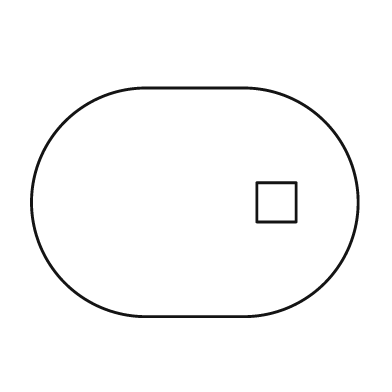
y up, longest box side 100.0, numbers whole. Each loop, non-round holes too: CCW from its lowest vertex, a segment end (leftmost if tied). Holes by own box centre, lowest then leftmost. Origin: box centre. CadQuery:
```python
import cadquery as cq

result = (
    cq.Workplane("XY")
    .moveTo(-15.0, -35.0)
    .lineTo(15.0, -35.0)
    .threePointArc((50.0, 0.0), (15.0, 35.0))
    .lineTo(-15.0, 35.0)
    .threePointArc((-50.0, 0.0), (-15.0, -35.0))
    .close()
    .moveTo(19.0, -6.0)
    .lineTo(31.0, -6.0)
    .lineTo(31.0, 6.0)
    .lineTo(19.0, 6.0)
    .close()
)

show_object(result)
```